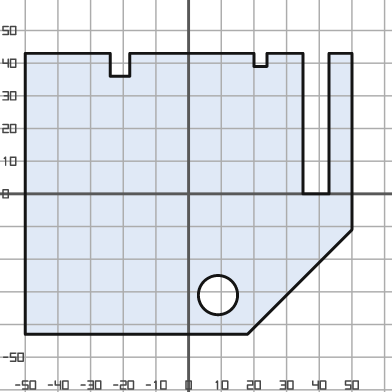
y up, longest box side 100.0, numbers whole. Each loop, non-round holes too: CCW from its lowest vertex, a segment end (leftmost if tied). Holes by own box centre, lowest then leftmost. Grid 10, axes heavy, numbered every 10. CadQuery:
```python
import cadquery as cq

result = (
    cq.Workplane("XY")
    .moveTo(-50.0, -43.0)
    .lineTo(18.0, -43.0)
    .lineTo(50.0, -11.0)
    .lineTo(50.0, 43.0)
    .lineTo(43.0, 43.0)
    .lineTo(43.0, 0.0)
    .lineTo(35.0, 0.0)
    .lineTo(35.0, 43.0)
    .lineTo(24.0, 43.0)
    .lineTo(24.0, 39.0)
    .lineTo(20.0, 39.0)
    .lineTo(20.0, 43.0)
    .lineTo(-18.0, 43.0)
    .lineTo(-18.0, 36.0)
    .lineTo(-24.0, 36.0)
    .lineTo(-24.0, 43.0)
    .lineTo(-50.0, 43.0)
    .close()
    .moveTo(9.0, -31.0)
    .circle(6.0)
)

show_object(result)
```